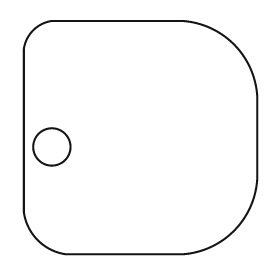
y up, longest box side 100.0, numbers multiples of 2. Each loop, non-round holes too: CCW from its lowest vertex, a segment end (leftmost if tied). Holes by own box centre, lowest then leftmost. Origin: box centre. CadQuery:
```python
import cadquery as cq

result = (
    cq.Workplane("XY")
    .moveTo(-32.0, -50.0)
    .lineTo(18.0, -50.0)
    .threePointArc((40.0, -40.0), (50.0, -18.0))
    .lineTo(50.0, 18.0)
    .threePointArc((40.0, 40.0), (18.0, 50.0))
    .lineTo(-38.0, 50.0)
    .threePointArc((-46.0, 46.0), (-50.0, 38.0))
    .lineTo(-50.0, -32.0)
    .threePointArc((-44.0, -44.0), (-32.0, -50.0))
    .close()
    .moveTo(-38.0, -4.0)
    .circle(8.0)
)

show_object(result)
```